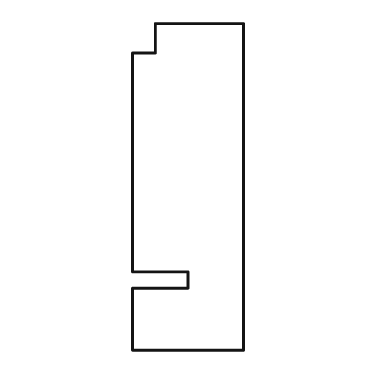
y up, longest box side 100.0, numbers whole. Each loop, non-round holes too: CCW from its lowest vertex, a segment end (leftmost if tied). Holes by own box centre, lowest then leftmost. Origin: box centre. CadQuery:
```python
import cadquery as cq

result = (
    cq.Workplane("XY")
    .moveTo(-17.0, -50.0)
    .lineTo(17.0, -50.0)
    .lineTo(17.0, 50.0)
    .lineTo(-10.0, 50.0)
    .lineTo(-10.0, 41.0)
    .lineTo(-17.0, 41.0)
    .lineTo(-17.0, -26.0)
    .lineTo(0.0, -26.0)
    .lineTo(0.0, -31.0)
    .lineTo(-17.0, -31.0)
    .close()
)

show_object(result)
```